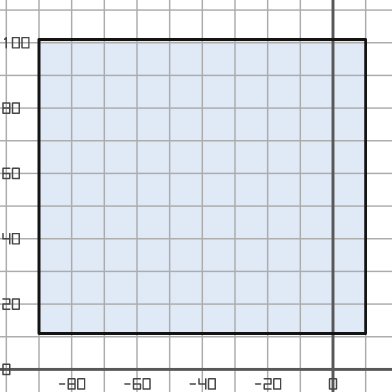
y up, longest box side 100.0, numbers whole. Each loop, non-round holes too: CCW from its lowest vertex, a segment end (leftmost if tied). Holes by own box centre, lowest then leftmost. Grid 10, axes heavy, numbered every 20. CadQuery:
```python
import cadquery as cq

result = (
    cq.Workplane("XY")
    .moveTo(-90.0, 11.0)
    .lineTo(10.0, 11.0)
    .lineTo(10.0, 101.0)
    .lineTo(-90.0, 101.0)
    .close()
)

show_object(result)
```